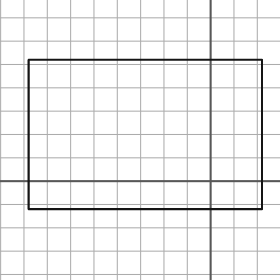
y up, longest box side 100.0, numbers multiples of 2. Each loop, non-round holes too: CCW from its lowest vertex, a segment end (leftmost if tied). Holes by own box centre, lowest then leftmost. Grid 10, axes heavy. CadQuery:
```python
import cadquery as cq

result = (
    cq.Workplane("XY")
    .moveTo(-78.0, -12.0)
    .lineTo(22.0, -12.0)
    .lineTo(22.0, 52.0)
    .lineTo(-78.0, 52.0)
    .close()
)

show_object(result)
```